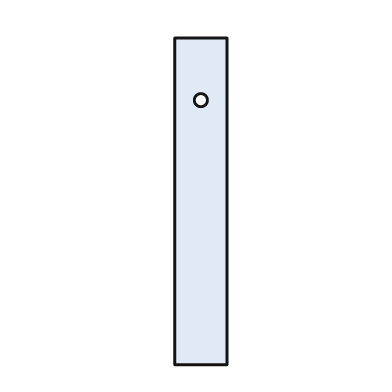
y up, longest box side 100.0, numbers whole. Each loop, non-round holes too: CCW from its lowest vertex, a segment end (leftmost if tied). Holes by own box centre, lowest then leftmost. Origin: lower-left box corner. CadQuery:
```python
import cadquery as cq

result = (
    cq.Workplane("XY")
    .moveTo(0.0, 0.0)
    .lineTo(16.0, 0.0)
    .lineTo(16.0, 100.0)
    .lineTo(0.0, 100.0)
    .close()
    .moveTo(8.0, 81.0)
    .circle(2.0)
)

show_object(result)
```